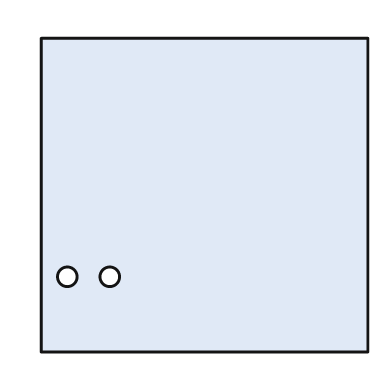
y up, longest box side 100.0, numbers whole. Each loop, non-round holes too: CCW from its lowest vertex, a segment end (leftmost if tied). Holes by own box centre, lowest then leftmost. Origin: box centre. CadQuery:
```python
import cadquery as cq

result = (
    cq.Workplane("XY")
    .moveTo(-50.0, -48.0)
    .lineTo(50.0, -48.0)
    .lineTo(50.0, 48.0)
    .lineTo(-50.0, 48.0)
    .close()
    .moveTo(-42.0, -25.0)
    .circle(3.0)
    .moveTo(-29.0, -25.0)
    .circle(3.0)
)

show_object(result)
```